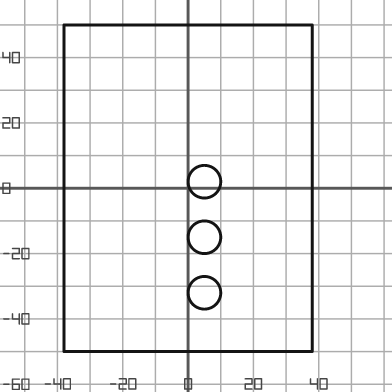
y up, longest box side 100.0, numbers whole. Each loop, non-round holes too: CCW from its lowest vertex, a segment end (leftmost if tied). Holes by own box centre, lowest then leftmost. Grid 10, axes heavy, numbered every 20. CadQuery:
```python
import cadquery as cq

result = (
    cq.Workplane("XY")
    .moveTo(-38.0, -50.0)
    .lineTo(38.0, -50.0)
    .lineTo(38.0, 50.0)
    .lineTo(-38.0, 50.0)
    .close()
    .moveTo(5.0, -32.0)
    .circle(5.0)
    .moveTo(5.0, -15.0)
    .circle(5.0)
    .moveTo(5.0, 2.0)
    .circle(5.0)
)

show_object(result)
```